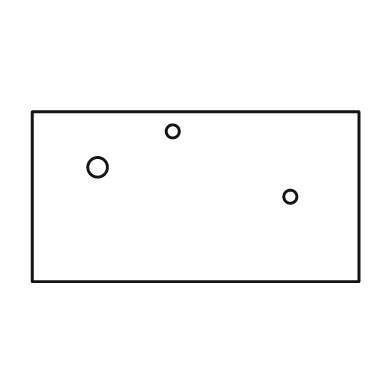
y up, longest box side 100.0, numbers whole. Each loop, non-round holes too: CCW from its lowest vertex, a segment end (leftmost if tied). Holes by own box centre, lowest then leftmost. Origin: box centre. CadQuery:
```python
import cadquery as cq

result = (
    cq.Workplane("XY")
    .moveTo(-50.0, -26.0)
    .lineTo(50.0, -26.0)
    .lineTo(50.0, 26.0)
    .lineTo(-50.0, 26.0)
    .close()
    .moveTo(29.0, 0.0)
    .circle(2.0)
    .moveTo(-30.0, 9.0)
    .circle(3.0)
    .moveTo(-7.0, 20.0)
    .circle(2.0)
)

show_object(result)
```